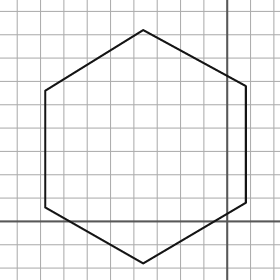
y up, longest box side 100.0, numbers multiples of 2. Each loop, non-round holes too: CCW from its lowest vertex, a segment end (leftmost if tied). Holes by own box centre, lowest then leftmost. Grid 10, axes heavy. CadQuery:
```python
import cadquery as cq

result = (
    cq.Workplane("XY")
    .moveTo(-36.0, -18.0)
    .lineTo(8.0, 8.0)
    .lineTo(8.0, 58.0)
    .lineTo(-36.0, 82.0)
    .lineTo(-78.0, 56.0)
    .lineTo(-78.0, 6.0)
    .close()
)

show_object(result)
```